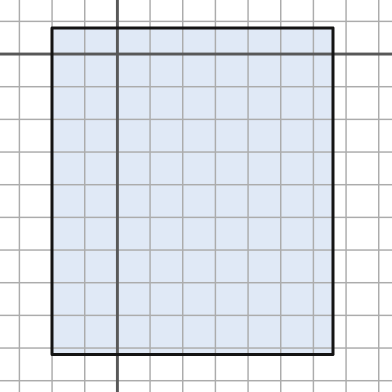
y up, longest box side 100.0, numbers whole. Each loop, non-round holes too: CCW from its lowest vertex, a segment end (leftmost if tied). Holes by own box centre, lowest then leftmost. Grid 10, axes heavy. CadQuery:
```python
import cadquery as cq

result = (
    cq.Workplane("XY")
    .moveTo(-20.0, -92.0)
    .lineTo(66.0, -92.0)
    .lineTo(66.0, 8.0)
    .lineTo(-20.0, 8.0)
    .close()
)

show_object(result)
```